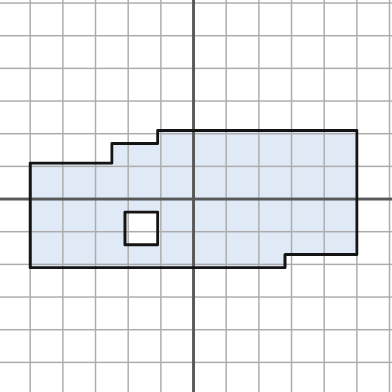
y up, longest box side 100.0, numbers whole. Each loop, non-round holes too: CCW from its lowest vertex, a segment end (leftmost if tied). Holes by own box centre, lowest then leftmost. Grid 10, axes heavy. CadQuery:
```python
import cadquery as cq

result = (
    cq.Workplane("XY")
    .moveTo(-50.0, -21.0)
    .lineTo(28.0, -21.0)
    .lineTo(28.0, -17.0)
    .lineTo(50.0, -17.0)
    .lineTo(50.0, 21.0)
    .lineTo(-11.0, 21.0)
    .lineTo(-11.0, 17.0)
    .lineTo(-25.0, 17.0)
    .lineTo(-25.0, 11.0)
    .lineTo(-50.0, 11.0)
    .close()
    .moveTo(-21.0, -14.0)
    .lineTo(-11.0, -14.0)
    .lineTo(-11.0, -4.0)
    .lineTo(-21.0, -4.0)
    .close()
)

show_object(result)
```